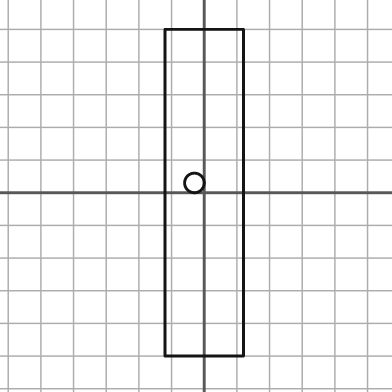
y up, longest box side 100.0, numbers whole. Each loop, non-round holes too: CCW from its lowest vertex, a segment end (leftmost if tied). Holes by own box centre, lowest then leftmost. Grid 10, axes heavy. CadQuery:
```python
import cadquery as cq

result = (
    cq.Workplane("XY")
    .moveTo(-12.0, -50.0)
    .lineTo(12.0, -50.0)
    .lineTo(12.0, 50.0)
    .lineTo(-12.0, 50.0)
    .close()
    .moveTo(-3.0, 3.0)
    .circle(3.0)
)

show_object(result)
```